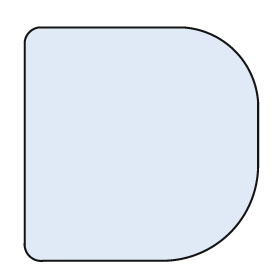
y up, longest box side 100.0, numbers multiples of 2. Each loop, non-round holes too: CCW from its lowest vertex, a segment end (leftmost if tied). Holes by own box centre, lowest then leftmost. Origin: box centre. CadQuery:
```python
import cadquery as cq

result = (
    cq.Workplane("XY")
    .moveTo(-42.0, -50.0)
    .lineTo(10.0, -50.0)
    .threePointArc((38.0, -38.0), (50.0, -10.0))
    .lineTo(50.0, 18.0)
    .threePointArc((40.0, 40.0), (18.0, 50.0))
    .lineTo(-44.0, 50.0)
    .threePointArc((-48.0, 48.0), (-50.0, 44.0))
    .lineTo(-50.0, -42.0)
    .threePointArc((-48.0, -48.0), (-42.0, -50.0))
    .close()
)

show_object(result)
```